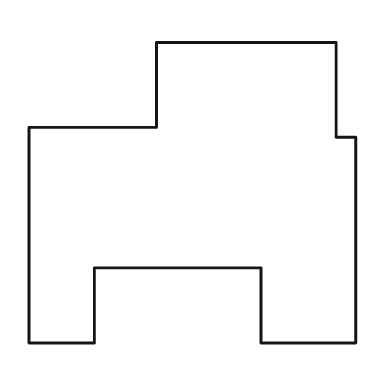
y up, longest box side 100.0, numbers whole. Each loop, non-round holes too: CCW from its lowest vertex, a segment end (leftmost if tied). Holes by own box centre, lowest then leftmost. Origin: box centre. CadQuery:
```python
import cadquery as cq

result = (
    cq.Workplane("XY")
    .moveTo(-50.0, -46.0)
    .lineTo(-30.0, -46.0)
    .lineTo(-30.0, -23.0)
    .lineTo(21.0, -23.0)
    .lineTo(21.0, -46.0)
    .lineTo(50.0, -46.0)
    .lineTo(50.0, 17.0)
    .lineTo(44.0, 17.0)
    .lineTo(44.0, 46.0)
    .lineTo(-11.0, 46.0)
    .lineTo(-11.0, 20.0)
    .lineTo(-50.0, 20.0)
    .close()
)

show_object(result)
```